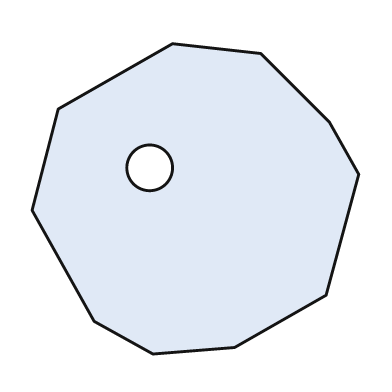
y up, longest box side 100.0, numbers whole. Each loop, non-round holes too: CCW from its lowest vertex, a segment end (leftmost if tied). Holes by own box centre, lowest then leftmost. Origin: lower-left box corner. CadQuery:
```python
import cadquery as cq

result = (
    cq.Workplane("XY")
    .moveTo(37.0, 0.0)
    .lineTo(62.0, 2.0)
    .lineTo(90.0, 18.0)
    .lineTo(100.0, 55.0)
    .lineTo(91.0, 71.0)
    .lineTo(70.0, 92.0)
    .lineTo(43.0, 95.0)
    .lineTo(8.0, 75.0)
    .lineTo(0.0, 44.0)
    .lineTo(19.0, 10.0)
    .close()
    .moveTo(36.0, 57.0)
    .circle(7.0)
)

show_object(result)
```